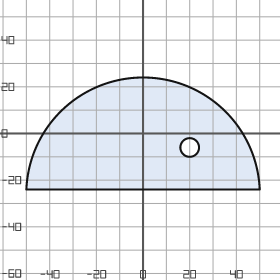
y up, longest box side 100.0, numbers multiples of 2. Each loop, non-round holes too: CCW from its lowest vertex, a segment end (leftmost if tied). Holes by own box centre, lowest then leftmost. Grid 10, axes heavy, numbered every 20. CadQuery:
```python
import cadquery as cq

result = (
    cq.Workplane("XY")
    .moveTo(-50.0, -24.0)
    .lineTo(50.0, -24.0)
    .threePointArc((0.0, 24.0), (-50.0, -24.0))
    .close()
    .moveTo(20.0, -6.0)
    .circle(4.0)
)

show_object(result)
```